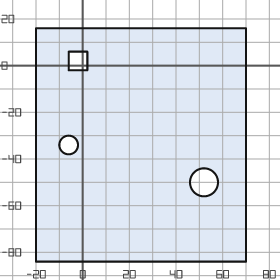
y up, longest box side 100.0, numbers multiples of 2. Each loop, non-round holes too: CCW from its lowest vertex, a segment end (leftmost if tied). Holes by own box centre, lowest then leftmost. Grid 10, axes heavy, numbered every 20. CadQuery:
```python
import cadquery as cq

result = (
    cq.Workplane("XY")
    .moveTo(-20.0, -84.0)
    .lineTo(70.0, -84.0)
    .lineTo(70.0, 16.0)
    .lineTo(-20.0, 16.0)
    .close()
    .moveTo(52.0, -50.0)
    .circle(6.0)
    .moveTo(-6.0, -34.0)
    .circle(4.0)
    .moveTo(-6.0, -2.0)
    .lineTo(2.0, -2.0)
    .lineTo(2.0, 6.0)
    .lineTo(-6.0, 6.0)
    .close()
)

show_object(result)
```